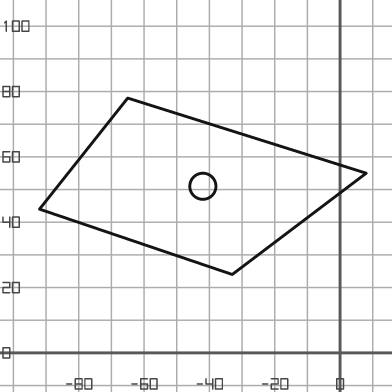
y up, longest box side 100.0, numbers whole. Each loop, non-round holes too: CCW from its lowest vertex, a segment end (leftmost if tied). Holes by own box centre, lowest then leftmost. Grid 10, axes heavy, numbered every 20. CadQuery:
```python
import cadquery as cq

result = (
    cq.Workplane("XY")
    .moveTo(-33.0, 24.0)
    .lineTo(8.0, 55.0)
    .lineTo(-65.0, 78.0)
    .lineTo(-92.0, 44.0)
    .close()
    .moveTo(-42.0, 51.0)
    .circle(4.0)
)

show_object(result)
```